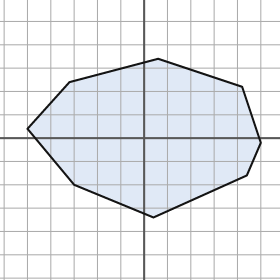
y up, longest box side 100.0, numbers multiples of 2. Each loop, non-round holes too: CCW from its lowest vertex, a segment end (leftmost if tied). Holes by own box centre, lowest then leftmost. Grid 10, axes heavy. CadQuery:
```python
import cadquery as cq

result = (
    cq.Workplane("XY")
    .moveTo(4.0, -34.0)
    .lineTo(44.0, -16.0)
    .lineTo(50.0, -2.0)
    .lineTo(42.0, 22.0)
    .lineTo(6.0, 34.0)
    .lineTo(-32.0, 24.0)
    .lineTo(-50.0, 4.0)
    .lineTo(-30.0, -20.0)
    .close()
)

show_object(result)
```